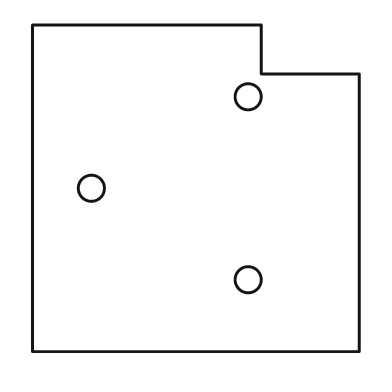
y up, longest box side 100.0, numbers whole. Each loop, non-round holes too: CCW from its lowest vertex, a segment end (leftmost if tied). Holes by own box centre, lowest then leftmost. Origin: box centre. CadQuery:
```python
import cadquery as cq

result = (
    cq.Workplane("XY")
    .moveTo(-50.0, -50.0)
    .lineTo(50.0, -50.0)
    .lineTo(50.0, 35.0)
    .lineTo(20.0, 35.0)
    .lineTo(20.0, 50.0)
    .lineTo(-50.0, 50.0)
    .close()
    .moveTo(16.0, -28.0)
    .circle(4.0)
    .moveTo(-32.0, 0.0)
    .circle(4.0)
    .moveTo(16.0, 28.0)
    .circle(4.0)
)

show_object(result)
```